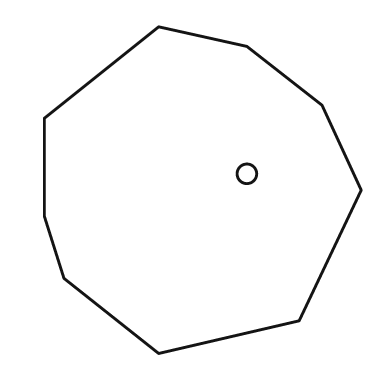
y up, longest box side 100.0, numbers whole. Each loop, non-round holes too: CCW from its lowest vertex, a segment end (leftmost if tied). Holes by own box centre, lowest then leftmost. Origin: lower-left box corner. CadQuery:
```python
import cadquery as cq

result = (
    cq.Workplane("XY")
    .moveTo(35.0, 0.0)
    .lineTo(78.0, 10.0)
    .lineTo(97.0, 50.0)
    .lineTo(85.0, 76.0)
    .lineTo(62.0, 94.0)
    .lineTo(35.0, 100.0)
    .lineTo(0.0, 72.0)
    .lineTo(0.0, 42.0)
    .lineTo(6.0, 23.0)
    .close()
    .moveTo(62.0, 55.0)
    .circle(3.0)
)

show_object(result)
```